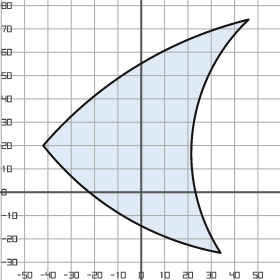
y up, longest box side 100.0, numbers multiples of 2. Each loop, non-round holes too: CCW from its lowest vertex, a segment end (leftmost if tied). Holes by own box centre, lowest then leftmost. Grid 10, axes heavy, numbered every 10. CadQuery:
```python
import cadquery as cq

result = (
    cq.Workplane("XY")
    .moveTo(34.0, -26.0)
    .threePointArc((22.0, 26.0), (46.0, 74.0))
    .threePointArc((-2.0, 54.0), (-42.0, 20.0))
    .threePointArc((-8.0, -10.0), (34.0, -26.0))
    .close()
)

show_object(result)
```